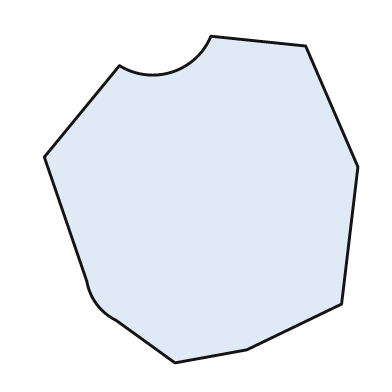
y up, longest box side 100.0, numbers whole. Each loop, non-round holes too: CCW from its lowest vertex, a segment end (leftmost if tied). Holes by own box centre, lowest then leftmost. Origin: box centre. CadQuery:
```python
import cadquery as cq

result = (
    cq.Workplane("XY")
    .moveTo(-8.0, -50.0)
    .lineTo(14.0, -46.0)
    .lineTo(43.0, -32.0)
    .lineTo(48.0, 10.0)
    .lineTo(32.0, 47.0)
    .lineTo(3.0, 50.0)
    .threePointArc((-9.0, 39.0), (-25.0, 41.0))
    .lineTo(-48.0, 13.0)
    .lineTo(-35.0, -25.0)
    .threePointArc((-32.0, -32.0), (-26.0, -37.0))
    .close()
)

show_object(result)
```